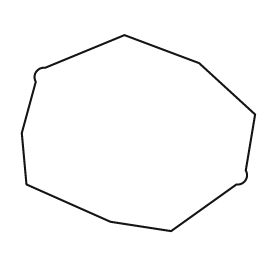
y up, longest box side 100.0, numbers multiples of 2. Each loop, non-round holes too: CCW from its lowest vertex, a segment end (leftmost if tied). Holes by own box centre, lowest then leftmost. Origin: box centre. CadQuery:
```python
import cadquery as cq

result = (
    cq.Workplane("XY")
    .moveTo(14.0, -42.0)
    .lineTo(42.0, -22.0)
    .threePointArc((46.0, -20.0), (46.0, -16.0))
    .lineTo(50.0, 8.0)
    .lineTo(26.0, 30.0)
    .lineTo(-6.0, 42.0)
    .lineTo(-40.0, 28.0)
    .threePointArc((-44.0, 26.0), (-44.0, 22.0))
    .lineTo(-50.0, 0.0)
    .lineTo(-48.0, -22.0)
    .lineTo(-12.0, -38.0)
    .close()
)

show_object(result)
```